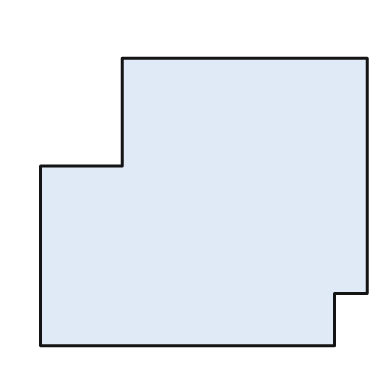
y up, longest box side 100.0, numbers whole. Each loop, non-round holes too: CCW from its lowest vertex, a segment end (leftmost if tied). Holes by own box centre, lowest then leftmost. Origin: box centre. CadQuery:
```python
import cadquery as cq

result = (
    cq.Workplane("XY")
    .moveTo(-50.0, -44.0)
    .lineTo(40.0, -44.0)
    .lineTo(40.0, -28.0)
    .lineTo(50.0, -28.0)
    .lineTo(50.0, 44.0)
    .lineTo(-25.0, 44.0)
    .lineTo(-25.0, 11.0)
    .lineTo(-50.0, 11.0)
    .close()
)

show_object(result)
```